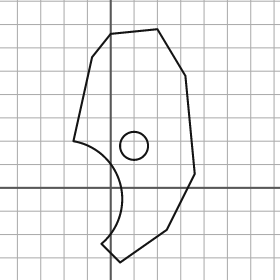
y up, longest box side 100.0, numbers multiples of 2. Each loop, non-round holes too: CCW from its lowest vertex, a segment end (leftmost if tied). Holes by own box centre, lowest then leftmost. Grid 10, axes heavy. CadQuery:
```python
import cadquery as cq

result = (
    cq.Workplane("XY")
    .moveTo(4.0, -32.0)
    .lineTo(24.0, -18.0)
    .lineTo(36.0, 6.0)
    .lineTo(32.0, 48.0)
    .lineTo(20.0, 68.0)
    .lineTo(0.0, 66.0)
    .lineTo(-8.0, 56.0)
    .lineTo(-16.0, 20.0)
    .threePointArc((4.0, 2.0), (-4.0, -24.0))
    .close()
    .moveTo(10.0, 18.0)
    .circle(6.0)
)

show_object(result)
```